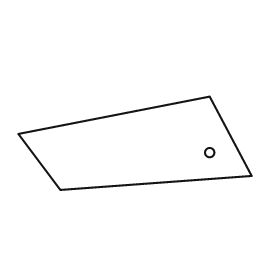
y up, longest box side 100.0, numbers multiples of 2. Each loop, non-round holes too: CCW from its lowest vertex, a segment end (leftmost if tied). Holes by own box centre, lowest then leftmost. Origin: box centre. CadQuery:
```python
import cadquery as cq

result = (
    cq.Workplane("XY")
    .moveTo(-32.0, -20.0)
    .lineTo(50.0, -14.0)
    .lineTo(32.0, 20.0)
    .lineTo(-50.0, 4.0)
    .close()
    .moveTo(32.0, -4.0)
    .circle(2.0)
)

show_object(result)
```